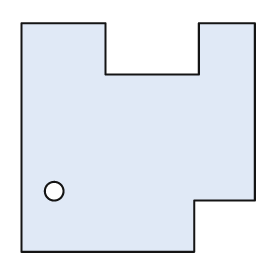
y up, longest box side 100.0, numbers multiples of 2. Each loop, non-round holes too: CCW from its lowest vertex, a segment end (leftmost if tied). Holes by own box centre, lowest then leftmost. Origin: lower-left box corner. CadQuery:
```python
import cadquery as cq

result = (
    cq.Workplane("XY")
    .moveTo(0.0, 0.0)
    .lineTo(74.0, 0.0)
    .lineTo(74.0, 22.0)
    .lineTo(100.0, 22.0)
    .lineTo(100.0, 98.0)
    .lineTo(76.0, 98.0)
    .lineTo(76.0, 76.0)
    .lineTo(36.0, 76.0)
    .lineTo(36.0, 98.0)
    .lineTo(0.0, 98.0)
    .close()
    .moveTo(14.0, 26.0)
    .circle(4.0)
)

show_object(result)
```